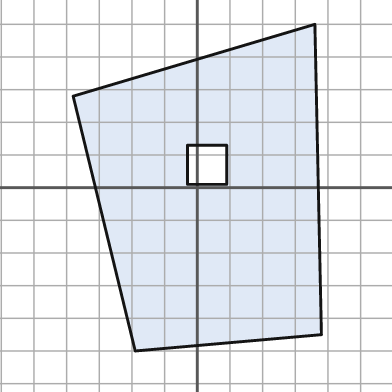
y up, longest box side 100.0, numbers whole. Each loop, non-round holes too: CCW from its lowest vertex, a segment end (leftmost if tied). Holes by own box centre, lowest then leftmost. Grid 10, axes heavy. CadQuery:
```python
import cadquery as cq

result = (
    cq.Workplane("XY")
    .moveTo(-19.0, -50.0)
    .lineTo(38.0, -45.0)
    .lineTo(36.0, 50.0)
    .lineTo(-38.0, 28.0)
    .close()
    .moveTo(-3.0, 1.0)
    .lineTo(9.0, 1.0)
    .lineTo(9.0, 13.0)
    .lineTo(-3.0, 13.0)
    .close()
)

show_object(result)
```